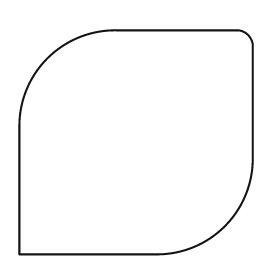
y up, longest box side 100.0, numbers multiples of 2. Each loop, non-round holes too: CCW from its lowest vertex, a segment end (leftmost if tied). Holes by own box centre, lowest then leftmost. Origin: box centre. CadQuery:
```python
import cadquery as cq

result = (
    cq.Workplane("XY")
    .moveTo(-50.0, -48.0)
    .lineTo(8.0, -48.0)
    .threePointArc((38.0, -36.0), (50.0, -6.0))
    .lineTo(50.0, 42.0)
    .threePointArc((48.0, 46.0), (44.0, 48.0))
    .lineTo(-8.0, 48.0)
    .threePointArc((-38.0, 36.0), (-50.0, 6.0))
    .close()
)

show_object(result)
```